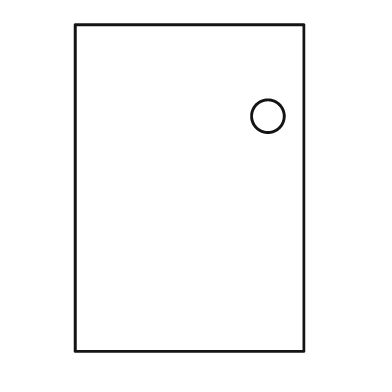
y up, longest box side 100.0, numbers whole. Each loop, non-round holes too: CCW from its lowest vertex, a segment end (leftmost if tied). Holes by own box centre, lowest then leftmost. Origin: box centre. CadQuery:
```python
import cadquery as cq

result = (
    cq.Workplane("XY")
    .moveTo(-35.0, -50.0)
    .lineTo(35.0, -50.0)
    .lineTo(35.0, 50.0)
    .lineTo(-35.0, 50.0)
    .close()
    .moveTo(24.0, 22.0)
    .circle(5.0)
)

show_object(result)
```